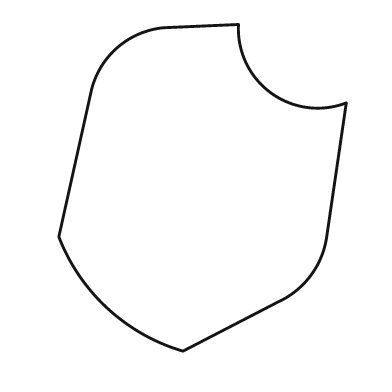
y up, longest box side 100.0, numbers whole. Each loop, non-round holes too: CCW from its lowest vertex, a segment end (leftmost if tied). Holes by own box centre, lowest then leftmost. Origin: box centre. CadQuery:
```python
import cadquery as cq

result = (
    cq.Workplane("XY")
    .moveTo(-6.0, -50.0)
    .lineTo(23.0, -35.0)
    .threePointArc((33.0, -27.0), (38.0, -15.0))
    .lineTo(44.0, 26.0)
    .threePointArc((21.0, 29.0), (11.0, 50.0))
    .lineTo(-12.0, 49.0)
    .threePointArc((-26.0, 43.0), (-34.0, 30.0))
    .lineTo(-44.0, -15.0)
    .threePointArc((-29.0, -37.0), (-6.0, -50.0))
    .close()
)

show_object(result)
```